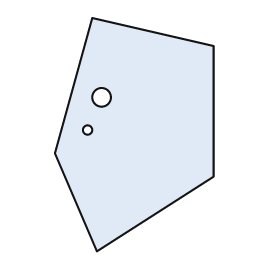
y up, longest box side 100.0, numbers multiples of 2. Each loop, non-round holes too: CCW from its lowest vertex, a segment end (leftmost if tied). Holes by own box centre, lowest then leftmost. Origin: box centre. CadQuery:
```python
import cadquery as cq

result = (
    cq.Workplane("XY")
    .moveTo(-16.0, -50.0)
    .lineTo(34.0, -18.0)
    .lineTo(34.0, 38.0)
    .lineTo(-18.0, 50.0)
    .lineTo(-34.0, -8.0)
    .close()
    .moveTo(-20.0, 2.0)
    .circle(2.0)
    .moveTo(-14.0, 16.0)
    .circle(4.0)
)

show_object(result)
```